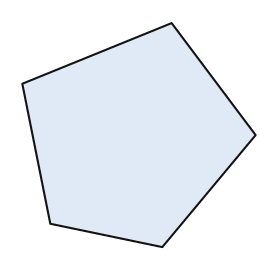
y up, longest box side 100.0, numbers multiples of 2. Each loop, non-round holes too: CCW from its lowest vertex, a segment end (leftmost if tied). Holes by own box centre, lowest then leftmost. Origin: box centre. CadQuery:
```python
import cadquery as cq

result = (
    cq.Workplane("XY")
    .moveTo(10.0, -48.0)
    .lineTo(50.0, 0.0)
    .lineTo(14.0, 48.0)
    .lineTo(-50.0, 22.0)
    .lineTo(-38.0, -38.0)
    .close()
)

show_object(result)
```